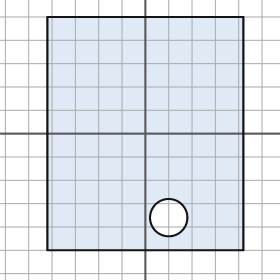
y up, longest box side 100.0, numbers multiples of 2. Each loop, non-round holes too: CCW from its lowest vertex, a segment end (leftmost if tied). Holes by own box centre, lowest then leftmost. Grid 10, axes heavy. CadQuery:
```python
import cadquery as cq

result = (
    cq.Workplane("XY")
    .moveTo(-42.0, -50.0)
    .lineTo(42.0, -50.0)
    .lineTo(42.0, 50.0)
    .lineTo(-42.0, 50.0)
    .close()
    .moveTo(10.0, -36.0)
    .circle(8.0)
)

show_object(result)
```